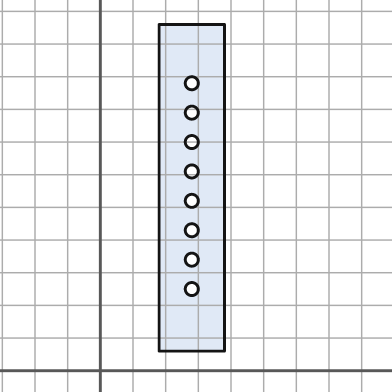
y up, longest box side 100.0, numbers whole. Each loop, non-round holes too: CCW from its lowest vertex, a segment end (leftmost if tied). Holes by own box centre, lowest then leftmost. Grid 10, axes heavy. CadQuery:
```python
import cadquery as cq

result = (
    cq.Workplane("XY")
    .moveTo(18.0, 6.0)
    .lineTo(38.0, 6.0)
    .lineTo(38.0, 106.0)
    .lineTo(18.0, 106.0)
    .close()
    .moveTo(28.0, 25.0)
    .circle(2.0)
    .moveTo(28.0, 34.0)
    .circle(2.0)
    .moveTo(28.0, 43.0)
    .circle(2.0)
    .moveTo(28.0, 52.0)
    .circle(2.0)
    .moveTo(28.0, 61.0)
    .circle(2.0)
    .moveTo(28.0, 70.0)
    .circle(2.0)
    .moveTo(28.0, 79.0)
    .circle(2.0)
    .moveTo(28.0, 88.0)
    .circle(2.0)
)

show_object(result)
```